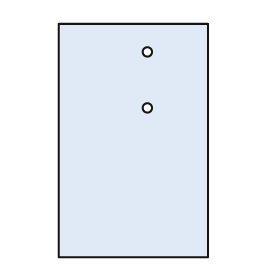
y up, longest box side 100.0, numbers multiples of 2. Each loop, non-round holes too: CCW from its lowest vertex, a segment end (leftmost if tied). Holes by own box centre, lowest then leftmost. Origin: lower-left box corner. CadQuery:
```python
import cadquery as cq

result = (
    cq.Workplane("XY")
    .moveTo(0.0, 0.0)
    .lineTo(64.0, 0.0)
    .lineTo(64.0, 100.0)
    .lineTo(0.0, 100.0)
    .close()
    .moveTo(38.0, 64.0)
    .circle(2.0)
    .moveTo(38.0, 88.0)
    .circle(2.0)
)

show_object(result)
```